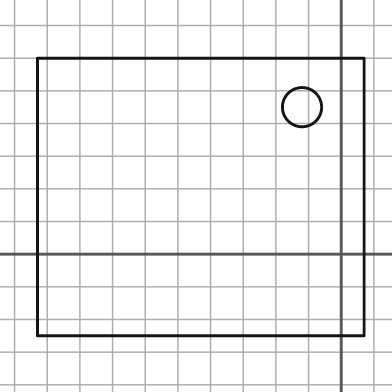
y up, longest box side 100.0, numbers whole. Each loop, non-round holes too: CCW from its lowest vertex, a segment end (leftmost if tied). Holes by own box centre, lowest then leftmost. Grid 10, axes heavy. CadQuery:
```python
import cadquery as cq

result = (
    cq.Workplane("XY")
    .moveTo(-93.0, -25.0)
    .lineTo(7.0, -25.0)
    .lineTo(7.0, 60.0)
    .lineTo(-93.0, 60.0)
    .close()
    .moveTo(-12.0, 45.0)
    .circle(6.0)
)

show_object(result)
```